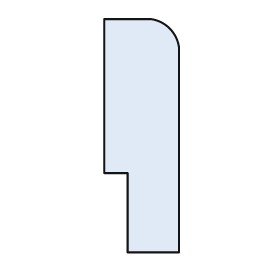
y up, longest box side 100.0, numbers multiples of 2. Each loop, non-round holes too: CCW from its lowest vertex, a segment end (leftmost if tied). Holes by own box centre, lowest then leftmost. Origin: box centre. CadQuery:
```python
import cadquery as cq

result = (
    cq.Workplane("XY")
    .moveTo(-6.0, -50.0)
    .lineTo(16.0, -50.0)
    .lineTo(16.0, 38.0)
    .threePointArc((12.0, 46.0), (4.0, 50.0))
    .lineTo(-16.0, 50.0)
    .lineTo(-16.0, -16.0)
    .lineTo(-6.0, -16.0)
    .close()
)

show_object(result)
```